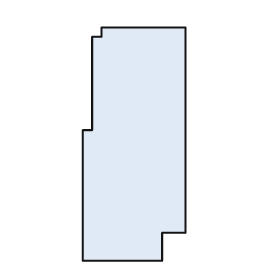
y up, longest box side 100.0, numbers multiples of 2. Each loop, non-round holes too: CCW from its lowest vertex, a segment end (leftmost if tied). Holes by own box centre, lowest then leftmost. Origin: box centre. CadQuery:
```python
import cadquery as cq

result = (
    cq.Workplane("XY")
    .moveTo(-22.0, -50.0)
    .lineTo(12.0, -50.0)
    .lineTo(12.0, -38.0)
    .lineTo(22.0, -38.0)
    .lineTo(22.0, 50.0)
    .lineTo(-14.0, 50.0)
    .lineTo(-14.0, 46.0)
    .lineTo(-18.0, 46.0)
    .lineTo(-18.0, 6.0)
    .lineTo(-22.0, 6.0)
    .close()
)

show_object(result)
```